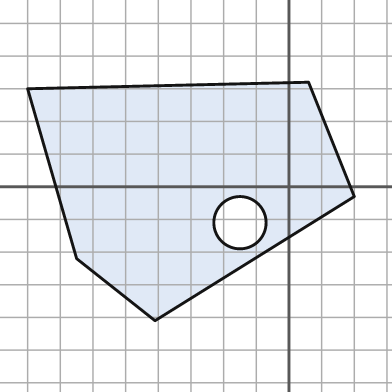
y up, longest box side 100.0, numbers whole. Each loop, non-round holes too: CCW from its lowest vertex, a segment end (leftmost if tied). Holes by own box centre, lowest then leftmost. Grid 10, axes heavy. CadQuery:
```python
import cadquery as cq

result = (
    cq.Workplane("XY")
    .moveTo(-41.0, -41.0)
    .lineTo(20.0, -3.0)
    .lineTo(6.0, 32.0)
    .lineTo(-80.0, 30.0)
    .lineTo(-65.0, -22.0)
    .close()
    .moveTo(-15.0, -11.0)
    .circle(8.0)
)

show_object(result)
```